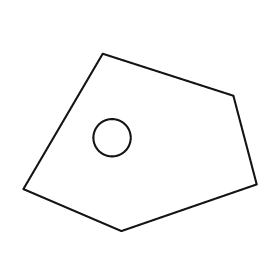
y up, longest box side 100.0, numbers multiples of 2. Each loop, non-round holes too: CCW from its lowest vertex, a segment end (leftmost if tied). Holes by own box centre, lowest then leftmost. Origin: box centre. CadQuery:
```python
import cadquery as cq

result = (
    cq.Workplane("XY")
    .moveTo(-8.0, -38.0)
    .lineTo(50.0, -18.0)
    .lineTo(40.0, 20.0)
    .lineTo(-16.0, 38.0)
    .lineTo(-50.0, -20.0)
    .close()
    .moveTo(-12.0, 2.0)
    .circle(8.0)
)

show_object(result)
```